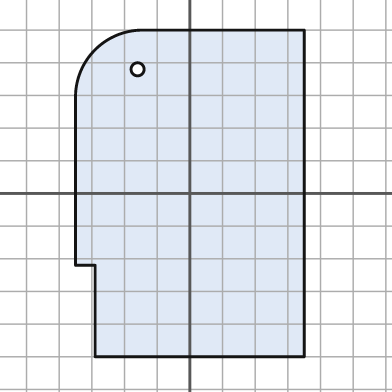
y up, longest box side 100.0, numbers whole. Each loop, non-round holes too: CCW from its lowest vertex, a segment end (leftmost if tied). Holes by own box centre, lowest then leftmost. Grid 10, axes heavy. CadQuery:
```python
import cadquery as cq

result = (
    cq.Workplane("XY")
    .moveTo(-29.0, -50.0)
    .lineTo(35.0, -50.0)
    .lineTo(35.0, 50.0)
    .lineTo(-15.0, 50.0)
    .threePointArc((-29.0, 44.0), (-35.0, 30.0))
    .lineTo(-35.0, -22.0)
    .lineTo(-29.0, -22.0)
    .close()
    .moveTo(-16.0, 38.0)
    .circle(2.0)
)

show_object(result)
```